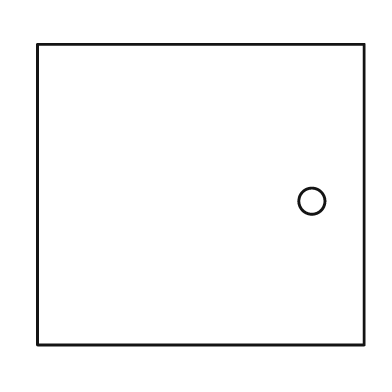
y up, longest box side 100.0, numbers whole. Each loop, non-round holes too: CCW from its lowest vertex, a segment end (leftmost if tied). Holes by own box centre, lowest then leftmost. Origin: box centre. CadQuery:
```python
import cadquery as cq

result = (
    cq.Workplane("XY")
    .moveTo(-50.0, -46.0)
    .lineTo(50.0, -46.0)
    .lineTo(50.0, 46.0)
    .lineTo(-50.0, 46.0)
    .close()
    .moveTo(34.0, -2.0)
    .circle(4.0)
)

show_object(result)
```